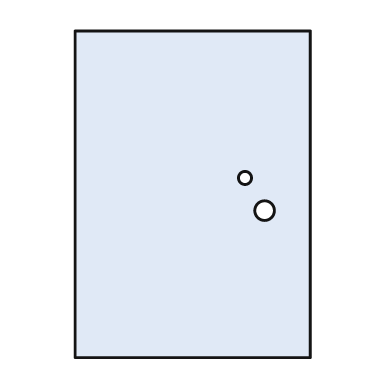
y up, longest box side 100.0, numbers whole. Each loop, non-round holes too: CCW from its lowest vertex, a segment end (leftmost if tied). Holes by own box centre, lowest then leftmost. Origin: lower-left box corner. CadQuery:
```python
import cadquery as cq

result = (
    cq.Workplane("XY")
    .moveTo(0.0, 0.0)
    .lineTo(72.0, 0.0)
    .lineTo(72.0, 100.0)
    .lineTo(0.0, 100.0)
    .close()
    .moveTo(58.0, 45.0)
    .circle(3.0)
    .moveTo(52.0, 55.0)
    .circle(2.0)
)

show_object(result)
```